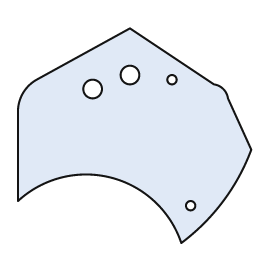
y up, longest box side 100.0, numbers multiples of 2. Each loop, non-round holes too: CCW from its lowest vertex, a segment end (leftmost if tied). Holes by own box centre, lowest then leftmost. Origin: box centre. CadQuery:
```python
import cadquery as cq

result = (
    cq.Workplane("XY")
    .moveTo(20.0, -46.0)
    .threePointArc((38.0, -28.0), (50.0, -6.0))
    .lineTo(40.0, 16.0)
    .threePointArc((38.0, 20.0), (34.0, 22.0))
    .lineTo(-2.0, 46.0)
    .lineTo(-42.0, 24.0)
    .threePointArc((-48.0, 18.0), (-50.0, 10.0))
    .lineTo(-50.0, -28.0)
    .threePointArc((-10.0, -18.0), (20.0, -46.0))
    .close()
    .moveTo(24.0, -30.0)
    .circle(2.0)
    .moveTo(-18.0, 20.0)
    .circle(4.0)
    .moveTo(16.0, 24.0)
    .circle(2.0)
    .moveTo(-2.0, 26.0)
    .circle(4.0)
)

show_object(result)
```